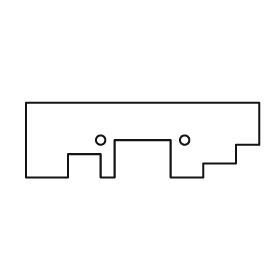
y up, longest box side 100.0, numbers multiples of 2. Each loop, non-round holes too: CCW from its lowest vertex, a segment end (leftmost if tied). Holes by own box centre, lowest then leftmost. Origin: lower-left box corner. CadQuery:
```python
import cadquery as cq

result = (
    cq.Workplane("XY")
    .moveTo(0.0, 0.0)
    .lineTo(18.0, 0.0)
    .lineTo(18.0, 10.0)
    .lineTo(32.0, 10.0)
    .lineTo(32.0, 0.0)
    .lineTo(38.0, 0.0)
    .lineTo(38.0, 16.0)
    .lineTo(62.0, 16.0)
    .lineTo(62.0, 0.0)
    .lineTo(76.0, 0.0)
    .lineTo(76.0, 6.0)
    .lineTo(90.0, 6.0)
    .lineTo(90.0, 14.0)
    .lineTo(100.0, 14.0)
    .lineTo(100.0, 32.0)
    .lineTo(0.0, 32.0)
    .close()
    .moveTo(32.0, 16.0)
    .circle(2.0)
    .moveTo(68.0, 16.0)
    .circle(2.0)
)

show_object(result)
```